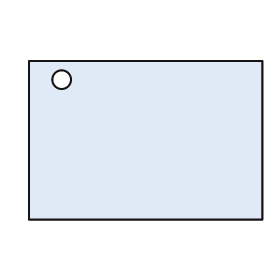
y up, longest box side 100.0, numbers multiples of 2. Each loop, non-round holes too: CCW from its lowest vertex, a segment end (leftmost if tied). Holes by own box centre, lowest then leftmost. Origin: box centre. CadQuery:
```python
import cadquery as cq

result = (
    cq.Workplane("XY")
    .moveTo(-50.0, -34.0)
    .lineTo(50.0, -34.0)
    .lineTo(50.0, 34.0)
    .lineTo(-50.0, 34.0)
    .close()
    .moveTo(-36.0, 26.0)
    .circle(4.0)
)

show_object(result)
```